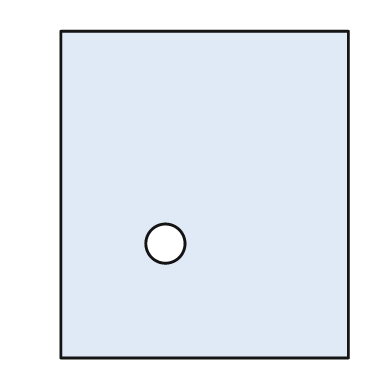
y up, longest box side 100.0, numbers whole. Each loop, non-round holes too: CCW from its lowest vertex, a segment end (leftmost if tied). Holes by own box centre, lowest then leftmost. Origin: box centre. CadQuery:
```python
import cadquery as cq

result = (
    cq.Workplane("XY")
    .moveTo(-44.0, -50.0)
    .lineTo(44.0, -50.0)
    .lineTo(44.0, 50.0)
    .lineTo(-44.0, 50.0)
    .close()
    .moveTo(-12.0, -15.0)
    .circle(6.0)
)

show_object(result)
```